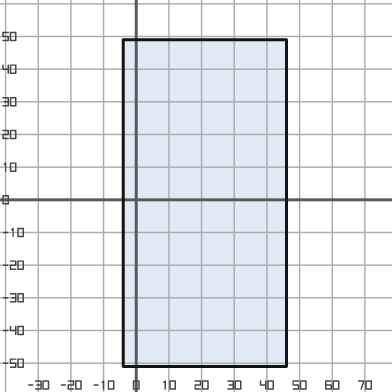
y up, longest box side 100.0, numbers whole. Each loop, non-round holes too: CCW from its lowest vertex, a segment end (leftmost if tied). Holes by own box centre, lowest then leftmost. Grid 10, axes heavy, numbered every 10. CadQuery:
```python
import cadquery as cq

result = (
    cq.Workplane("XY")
    .moveTo(-4.0, -51.0)
    .lineTo(46.0, -51.0)
    .lineTo(46.0, 49.0)
    .lineTo(-4.0, 49.0)
    .close()
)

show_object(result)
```